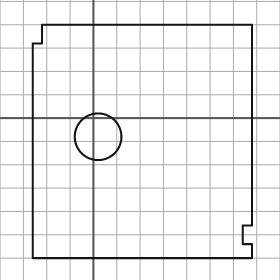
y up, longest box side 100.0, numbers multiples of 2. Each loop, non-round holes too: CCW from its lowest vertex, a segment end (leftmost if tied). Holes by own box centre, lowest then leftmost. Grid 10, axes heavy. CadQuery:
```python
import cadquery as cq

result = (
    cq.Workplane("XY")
    .moveTo(-26.0, -60.0)
    .lineTo(68.0, -60.0)
    .lineTo(68.0, -54.0)
    .lineTo(64.0, -54.0)
    .lineTo(64.0, -46.0)
    .lineTo(68.0, -46.0)
    .lineTo(68.0, 40.0)
    .lineTo(-22.0, 40.0)
    .lineTo(-22.0, 32.0)
    .lineTo(-26.0, 32.0)
    .close()
    .moveTo(2.0, -8.0)
    .circle(10.0)
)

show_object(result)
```